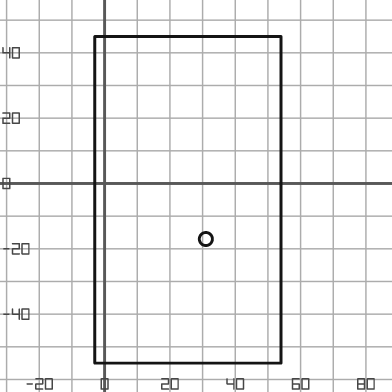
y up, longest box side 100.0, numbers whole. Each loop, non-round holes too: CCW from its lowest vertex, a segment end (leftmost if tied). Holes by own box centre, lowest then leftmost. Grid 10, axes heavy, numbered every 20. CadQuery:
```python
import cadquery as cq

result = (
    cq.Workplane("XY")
    .moveTo(-3.0, -55.0)
    .lineTo(54.0, -55.0)
    .lineTo(54.0, 45.0)
    .lineTo(-3.0, 45.0)
    .close()
    .moveTo(31.0, -17.0)
    .circle(2.0)
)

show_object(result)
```